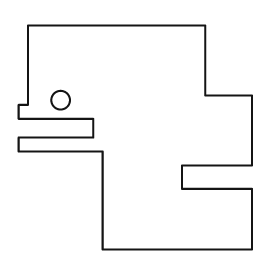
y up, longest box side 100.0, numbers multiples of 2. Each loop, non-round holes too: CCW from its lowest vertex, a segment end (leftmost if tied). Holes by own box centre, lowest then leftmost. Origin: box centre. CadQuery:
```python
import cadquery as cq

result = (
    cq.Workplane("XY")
    .moveTo(-14.0, -48.0)
    .lineTo(50.0, -48.0)
    .lineTo(50.0, -22.0)
    .lineTo(20.0, -22.0)
    .lineTo(20.0, -12.0)
    .lineTo(50.0, -12.0)
    .lineTo(50.0, 18.0)
    .lineTo(30.0, 18.0)
    .lineTo(30.0, 48.0)
    .lineTo(-46.0, 48.0)
    .lineTo(-46.0, 14.0)
    .lineTo(-50.0, 14.0)
    .lineTo(-50.0, 8.0)
    .lineTo(-18.0, 8.0)
    .lineTo(-18.0, 0.0)
    .lineTo(-50.0, 0.0)
    .lineTo(-50.0, -6.0)
    .lineTo(-14.0, -6.0)
    .close()
    .moveTo(-32.0, 16.0)
    .circle(4.0)
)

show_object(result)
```